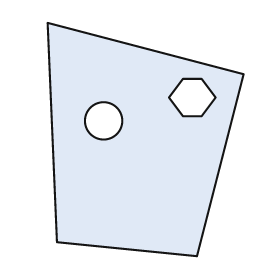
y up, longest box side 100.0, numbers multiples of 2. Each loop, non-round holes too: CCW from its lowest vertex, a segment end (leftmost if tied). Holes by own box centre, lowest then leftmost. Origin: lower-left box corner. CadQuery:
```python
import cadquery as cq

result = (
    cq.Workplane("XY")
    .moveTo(64.0, 0.0)
    .lineTo(84.0, 78.0)
    .lineTo(0.0, 100.0)
    .lineTo(4.0, 6.0)
    .close()
    .moveTo(24.0, 58.0)
    .circle(8.0)
    .moveTo(58.0, 60.0)
    .lineTo(66.0, 60.0)
    .lineTo(72.0, 68.0)
    .lineTo(66.0, 76.0)
    .lineTo(58.0, 76.0)
    .lineTo(52.0, 68.0)
    .close()
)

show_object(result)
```